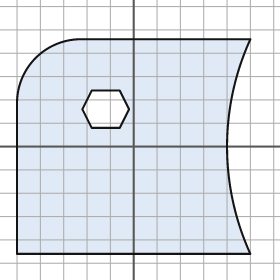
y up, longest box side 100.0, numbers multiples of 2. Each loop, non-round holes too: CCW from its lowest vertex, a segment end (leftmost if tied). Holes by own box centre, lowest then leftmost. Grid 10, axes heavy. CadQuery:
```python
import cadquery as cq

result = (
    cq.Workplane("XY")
    .moveTo(-50.0, -46.0)
    .lineTo(50.0, -46.0)
    .threePointArc((40.0, 0.0), (50.0, 46.0))
    .lineTo(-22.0, 46.0)
    .threePointArc((-42.0, 38.0), (-50.0, 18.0))
    .close()
    .moveTo(-18.0, 8.0)
    .lineTo(-6.0, 8.0)
    .lineTo(-2.0, 16.0)
    .lineTo(-6.0, 24.0)
    .lineTo(-18.0, 24.0)
    .lineTo(-22.0, 16.0)
    .close()
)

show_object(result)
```